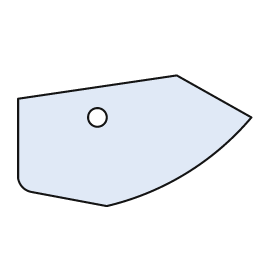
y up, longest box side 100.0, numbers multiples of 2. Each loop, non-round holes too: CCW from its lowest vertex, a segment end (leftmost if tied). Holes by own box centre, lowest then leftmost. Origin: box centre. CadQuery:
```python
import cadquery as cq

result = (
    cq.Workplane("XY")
    .moveTo(-12.0, -28.0)
    .threePointArc((22.0, -14.0), (50.0, 10.0))
    .lineTo(18.0, 28.0)
    .lineTo(-50.0, 18.0)
    .lineTo(-50.0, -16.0)
    .threePointArc((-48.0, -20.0), (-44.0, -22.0))
    .close()
    .moveTo(-16.0, 10.0)
    .circle(4.0)
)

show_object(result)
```